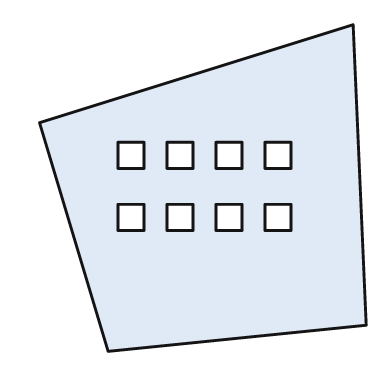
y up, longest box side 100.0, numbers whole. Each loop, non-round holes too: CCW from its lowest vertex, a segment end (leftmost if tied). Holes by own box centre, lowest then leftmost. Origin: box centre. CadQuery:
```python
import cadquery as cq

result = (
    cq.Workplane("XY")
    .moveTo(-29.0, -50.0)
    .lineTo(50.0, -42.0)
    .lineTo(46.0, 50.0)
    .lineTo(-50.0, 20.0)
    .close()
    .moveTo(-26.0, -13.0)
    .lineTo(-18.0, -13.0)
    .lineTo(-18.0, -5.0)
    .lineTo(-26.0, -5.0)
    .close()
    .moveTo(-11.0, -13.0)
    .lineTo(-3.0, -13.0)
    .lineTo(-3.0, -5.0)
    .lineTo(-11.0, -5.0)
    .close()
    .moveTo(4.0, -13.0)
    .lineTo(12.0, -13.0)
    .lineTo(12.0, -5.0)
    .lineTo(4.0, -5.0)
    .close()
    .moveTo(19.0, -13.0)
    .lineTo(27.0, -13.0)
    .lineTo(27.0, -5.0)
    .lineTo(19.0, -5.0)
    .close()
    .moveTo(-26.0, 6.0)
    .lineTo(-18.0, 6.0)
    .lineTo(-18.0, 14.0)
    .lineTo(-26.0, 14.0)
    .close()
    .moveTo(-11.0, 6.0)
    .lineTo(-3.0, 6.0)
    .lineTo(-3.0, 14.0)
    .lineTo(-11.0, 14.0)
    .close()
    .moveTo(4.0, 6.0)
    .lineTo(12.0, 6.0)
    .lineTo(12.0, 14.0)
    .lineTo(4.0, 14.0)
    .close()
    .moveTo(19.0, 6.0)
    .lineTo(27.0, 6.0)
    .lineTo(27.0, 14.0)
    .lineTo(19.0, 14.0)
    .close()
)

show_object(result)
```